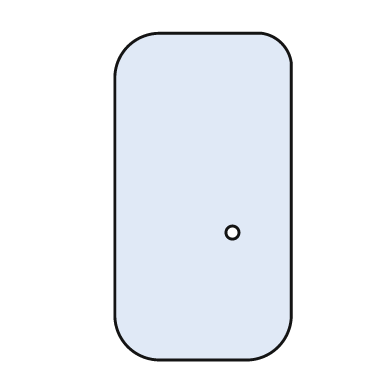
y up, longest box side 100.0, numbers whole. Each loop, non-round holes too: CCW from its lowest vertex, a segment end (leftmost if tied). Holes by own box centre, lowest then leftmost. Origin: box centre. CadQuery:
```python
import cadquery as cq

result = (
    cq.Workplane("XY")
    .moveTo(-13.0, -50.0)
    .lineTo(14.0, -50.0)
    .threePointArc((23.0, -46.0), (27.0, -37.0))
    .lineTo(27.0, 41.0)
    .threePointArc((24.0, 47.0), (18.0, 50.0))
    .lineTo(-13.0, 50.0)
    .threePointArc((-23.0, 46.0), (-27.0, 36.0))
    .lineTo(-27.0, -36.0)
    .threePointArc((-23.0, -46.0), (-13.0, -50.0))
    .close()
    .moveTo(9.0, -11.0)
    .circle(2.0)
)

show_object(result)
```